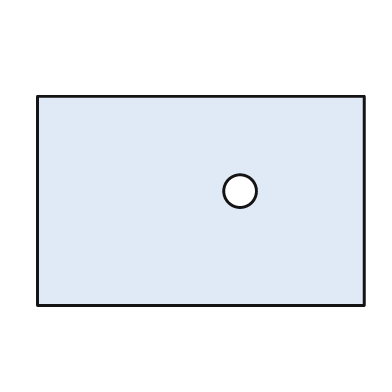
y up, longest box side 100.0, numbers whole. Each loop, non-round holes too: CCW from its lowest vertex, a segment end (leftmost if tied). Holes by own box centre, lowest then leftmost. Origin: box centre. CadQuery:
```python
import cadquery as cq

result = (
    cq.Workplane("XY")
    .moveTo(-50.0, -32.0)
    .lineTo(50.0, -32.0)
    .lineTo(50.0, 32.0)
    .lineTo(-50.0, 32.0)
    .close()
    .moveTo(12.0, 3.0)
    .circle(5.0)
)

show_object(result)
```